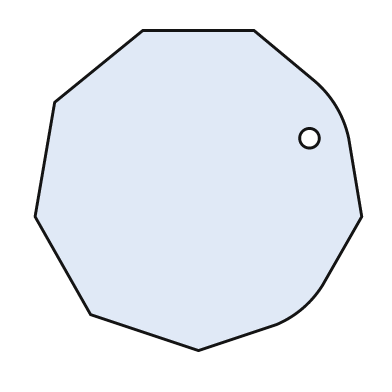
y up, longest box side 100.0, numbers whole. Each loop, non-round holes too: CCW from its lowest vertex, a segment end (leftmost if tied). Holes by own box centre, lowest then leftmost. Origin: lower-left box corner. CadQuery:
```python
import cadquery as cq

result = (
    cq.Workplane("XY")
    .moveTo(50.0, 0.0)
    .lineTo(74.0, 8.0)
    .threePointArc((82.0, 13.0), (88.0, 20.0))
    .lineTo(100.0, 41.0)
    .lineTo(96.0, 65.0)
    .threePointArc((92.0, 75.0), (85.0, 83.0))
    .lineTo(67.0, 98.0)
    .lineTo(33.0, 98.0)
    .lineTo(6.0, 76.0)
    .lineTo(0.0, 41.0)
    .lineTo(17.0, 11.0)
    .close()
    .moveTo(84.0, 65.0)
    .circle(3.0)
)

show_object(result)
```